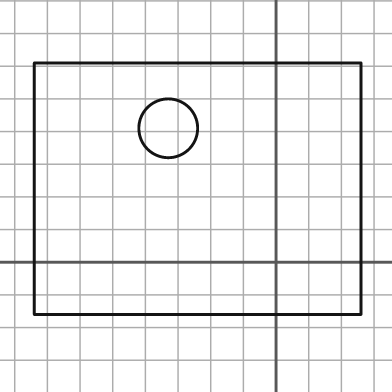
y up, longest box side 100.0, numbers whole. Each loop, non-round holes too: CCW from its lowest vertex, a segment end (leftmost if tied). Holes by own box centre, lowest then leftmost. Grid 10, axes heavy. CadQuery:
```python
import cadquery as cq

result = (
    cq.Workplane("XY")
    .moveTo(-74.0, -16.0)
    .lineTo(26.0, -16.0)
    .lineTo(26.0, 61.0)
    .lineTo(-74.0, 61.0)
    .close()
    .moveTo(-33.0, 41.0)
    .circle(9.0)
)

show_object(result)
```